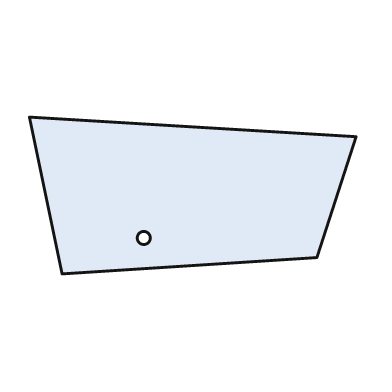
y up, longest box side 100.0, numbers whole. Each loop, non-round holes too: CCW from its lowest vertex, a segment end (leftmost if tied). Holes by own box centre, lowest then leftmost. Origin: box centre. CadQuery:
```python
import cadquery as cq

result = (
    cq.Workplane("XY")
    .moveTo(-40.0, -24.0)
    .lineTo(38.0, -19.0)
    .lineTo(50.0, 18.0)
    .lineTo(-50.0, 24.0)
    .close()
    .moveTo(-15.0, -13.0)
    .circle(2.0)
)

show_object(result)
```